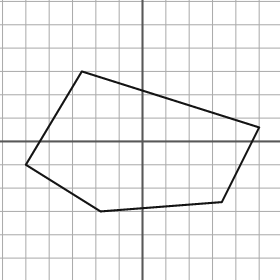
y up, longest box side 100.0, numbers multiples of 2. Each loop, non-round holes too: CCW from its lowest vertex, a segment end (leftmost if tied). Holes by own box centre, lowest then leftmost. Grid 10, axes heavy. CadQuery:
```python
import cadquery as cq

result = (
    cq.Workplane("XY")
    .moveTo(-18.0, -30.0)
    .lineTo(34.0, -26.0)
    .lineTo(50.0, 6.0)
    .lineTo(-26.0, 30.0)
    .lineTo(-50.0, -10.0)
    .close()
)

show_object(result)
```